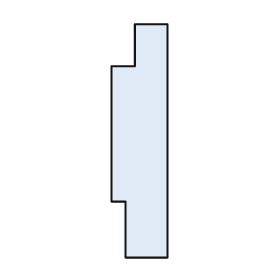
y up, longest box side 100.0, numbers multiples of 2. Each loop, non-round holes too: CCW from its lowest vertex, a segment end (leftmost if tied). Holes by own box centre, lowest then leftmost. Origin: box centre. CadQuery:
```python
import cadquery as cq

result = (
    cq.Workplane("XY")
    .moveTo(-6.0, -50.0)
    .lineTo(12.0, -50.0)
    .lineTo(12.0, 50.0)
    .lineTo(-2.0, 50.0)
    .lineTo(-2.0, 32.0)
    .lineTo(-12.0, 32.0)
    .lineTo(-12.0, -26.0)
    .lineTo(-6.0, -26.0)
    .close()
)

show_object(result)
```